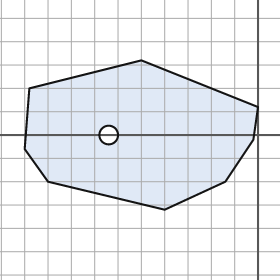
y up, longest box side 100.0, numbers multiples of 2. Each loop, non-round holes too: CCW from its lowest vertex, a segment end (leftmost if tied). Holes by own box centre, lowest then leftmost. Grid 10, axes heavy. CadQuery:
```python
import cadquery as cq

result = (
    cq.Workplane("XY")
    .moveTo(-40.0, -32.0)
    .lineTo(-14.0, -20.0)
    .lineTo(-2.0, -2.0)
    .lineTo(0.0, 12.0)
    .lineTo(-50.0, 32.0)
    .lineTo(-98.0, 20.0)
    .lineTo(-100.0, -6.0)
    .lineTo(-90.0, -20.0)
    .close()
    .moveTo(-64.0, 0.0)
    .circle(4.0)
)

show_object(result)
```